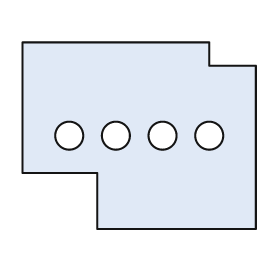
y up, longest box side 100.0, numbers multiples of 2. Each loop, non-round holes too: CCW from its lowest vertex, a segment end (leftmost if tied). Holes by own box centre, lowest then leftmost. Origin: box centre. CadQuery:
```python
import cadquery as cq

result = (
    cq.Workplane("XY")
    .moveTo(-18.0, -40.0)
    .lineTo(50.0, -40.0)
    .lineTo(50.0, 30.0)
    .lineTo(30.0, 30.0)
    .lineTo(30.0, 40.0)
    .lineTo(-50.0, 40.0)
    .lineTo(-50.0, -16.0)
    .lineTo(-18.0, -16.0)
    .close()
    .moveTo(-30.0, 0.0)
    .circle(6.0)
    .moveTo(-10.0, 0.0)
    .circle(6.0)
    .moveTo(10.0, 0.0)
    .circle(6.0)
    .moveTo(30.0, 0.0)
    .circle(6.0)
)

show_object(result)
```